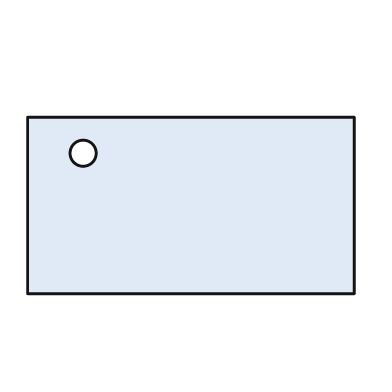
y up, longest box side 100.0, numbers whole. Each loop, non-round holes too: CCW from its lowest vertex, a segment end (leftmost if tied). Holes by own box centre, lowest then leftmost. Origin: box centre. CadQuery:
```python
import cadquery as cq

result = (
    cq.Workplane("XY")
    .moveTo(-50.0, -27.0)
    .lineTo(50.0, -27.0)
    .lineTo(50.0, 27.0)
    .lineTo(-50.0, 27.0)
    .close()
    .moveTo(-33.0, 16.0)
    .circle(4.0)
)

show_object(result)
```